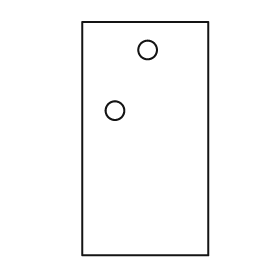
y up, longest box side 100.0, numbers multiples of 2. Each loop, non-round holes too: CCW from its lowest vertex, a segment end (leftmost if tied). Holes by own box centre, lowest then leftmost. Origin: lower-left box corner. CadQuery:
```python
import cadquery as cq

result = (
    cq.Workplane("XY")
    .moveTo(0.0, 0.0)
    .lineTo(54.0, 0.0)
    .lineTo(54.0, 100.0)
    .lineTo(0.0, 100.0)
    .close()
    .moveTo(14.0, 62.0)
    .circle(4.0)
    .moveTo(28.0, 88.0)
    .circle(4.0)
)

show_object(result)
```